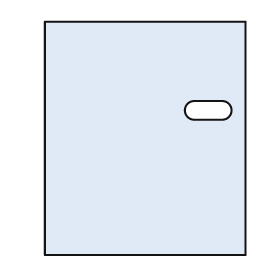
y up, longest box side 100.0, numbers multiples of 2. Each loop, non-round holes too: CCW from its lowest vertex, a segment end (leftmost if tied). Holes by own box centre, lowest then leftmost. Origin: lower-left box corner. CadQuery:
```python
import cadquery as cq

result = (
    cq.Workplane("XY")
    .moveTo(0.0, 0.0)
    .lineTo(86.0, 0.0)
    .lineTo(86.0, 100.0)
    .lineTo(0.0, 100.0)
    .close()
    .moveTo(64.0, 58.0)
    .lineTo(76.0, 58.0)
    .threePointArc((80.0, 62.0), (76.0, 66.0))
    .lineTo(64.0, 66.0)
    .threePointArc((60.0, 62.0), (64.0, 58.0))
    .close()
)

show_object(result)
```